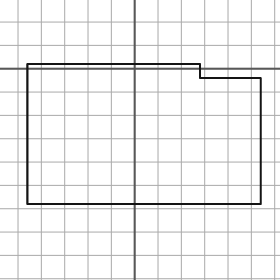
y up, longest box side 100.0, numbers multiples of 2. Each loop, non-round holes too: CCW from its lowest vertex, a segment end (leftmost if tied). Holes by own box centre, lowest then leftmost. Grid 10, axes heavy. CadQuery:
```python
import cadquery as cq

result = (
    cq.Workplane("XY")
    .moveTo(-46.0, -58.0)
    .lineTo(54.0, -58.0)
    .lineTo(54.0, -4.0)
    .lineTo(28.0, -4.0)
    .lineTo(28.0, 2.0)
    .lineTo(-46.0, 2.0)
    .close()
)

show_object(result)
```